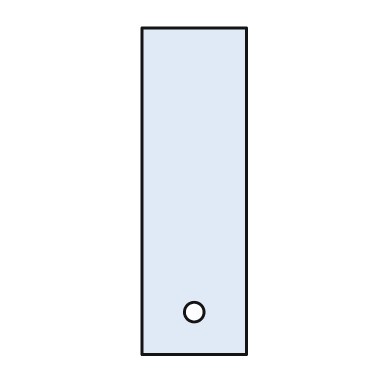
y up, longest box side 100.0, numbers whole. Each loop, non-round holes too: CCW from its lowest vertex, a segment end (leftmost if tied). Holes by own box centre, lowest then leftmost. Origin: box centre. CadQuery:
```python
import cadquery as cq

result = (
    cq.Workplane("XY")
    .moveTo(-16.0, -50.0)
    .lineTo(16.0, -50.0)
    .lineTo(16.0, 50.0)
    .lineTo(-16.0, 50.0)
    .close()
    .moveTo(0.0, -37.0)
    .circle(3.0)
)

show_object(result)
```